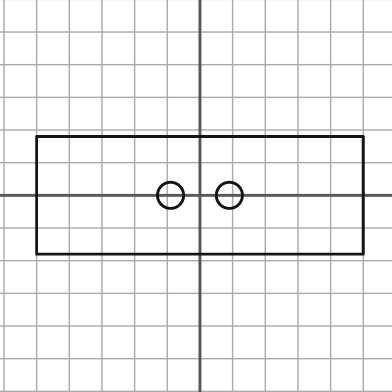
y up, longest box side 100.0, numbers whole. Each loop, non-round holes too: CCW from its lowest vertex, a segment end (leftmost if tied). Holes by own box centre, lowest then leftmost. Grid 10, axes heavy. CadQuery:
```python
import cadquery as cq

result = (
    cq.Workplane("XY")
    .moveTo(-50.0, -18.0)
    .lineTo(50.0, -18.0)
    .lineTo(50.0, 18.0)
    .lineTo(-50.0, 18.0)
    .close()
    .moveTo(-9.0, 0.0)
    .circle(4.0)
    .moveTo(9.0, 0.0)
    .circle(4.0)
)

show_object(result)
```